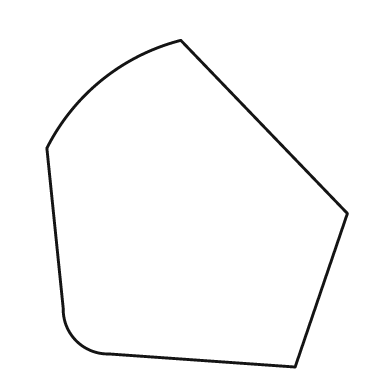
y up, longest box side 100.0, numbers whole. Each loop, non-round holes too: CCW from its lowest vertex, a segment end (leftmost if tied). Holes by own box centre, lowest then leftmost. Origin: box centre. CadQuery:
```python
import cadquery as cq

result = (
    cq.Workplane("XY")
    .moveTo(30.0, -50.0)
    .lineTo(46.0, -3.0)
    .lineTo(-5.0, 50.0)
    .threePointArc((-29.0, 38.0), (-46.0, 17.0))
    .lineTo(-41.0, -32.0)
    .threePointArc((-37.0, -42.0), (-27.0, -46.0))
    .close()
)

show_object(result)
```